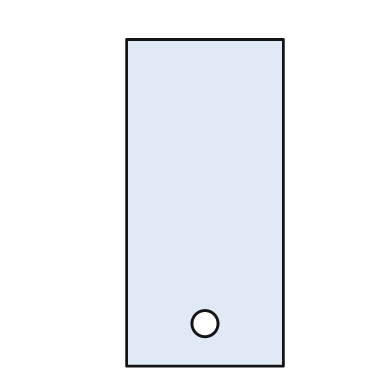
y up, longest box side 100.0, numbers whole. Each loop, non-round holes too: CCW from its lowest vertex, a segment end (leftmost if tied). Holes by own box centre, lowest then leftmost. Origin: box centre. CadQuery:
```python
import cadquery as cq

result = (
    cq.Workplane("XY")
    .moveTo(-24.0, -50.0)
    .lineTo(24.0, -50.0)
    .lineTo(24.0, 50.0)
    .lineTo(-24.0, 50.0)
    .close()
    .moveTo(0.0, -37.0)
    .circle(4.0)
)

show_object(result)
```